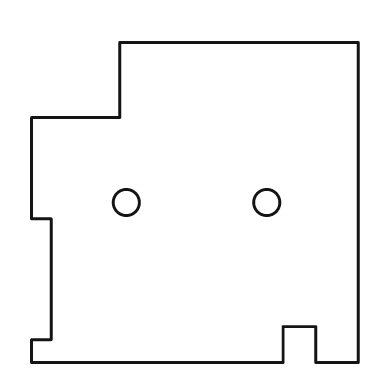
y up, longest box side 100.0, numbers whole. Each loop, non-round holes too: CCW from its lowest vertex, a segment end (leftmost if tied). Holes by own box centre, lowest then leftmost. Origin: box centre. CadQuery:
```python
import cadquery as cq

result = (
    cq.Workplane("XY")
    .moveTo(-50.0, -49.0)
    .lineTo(27.0, -49.0)
    .lineTo(27.0, -38.0)
    .lineTo(37.0, -38.0)
    .lineTo(37.0, -49.0)
    .lineTo(50.0, -49.0)
    .lineTo(50.0, 49.0)
    .lineTo(-23.0, 49.0)
    .lineTo(-23.0, 26.0)
    .lineTo(-50.0, 26.0)
    .lineTo(-50.0, -5.0)
    .lineTo(-44.0, -5.0)
    .lineTo(-44.0, -42.0)
    .lineTo(-50.0, -42.0)
    .close()
    .moveTo(-21.0, 0.0)
    .circle(4.0)
    .moveTo(22.0, 0.0)
    .circle(4.0)
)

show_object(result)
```